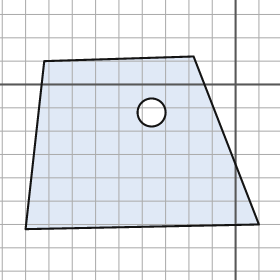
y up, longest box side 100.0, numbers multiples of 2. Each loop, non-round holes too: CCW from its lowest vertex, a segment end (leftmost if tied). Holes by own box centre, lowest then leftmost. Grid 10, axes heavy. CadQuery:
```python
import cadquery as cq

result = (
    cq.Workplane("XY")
    .moveTo(-90.0, -62.0)
    .lineTo(10.0, -60.0)
    .lineTo(-18.0, 12.0)
    .lineTo(-82.0, 10.0)
    .close()
    .moveTo(-36.0, -12.0)
    .circle(6.0)
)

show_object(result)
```